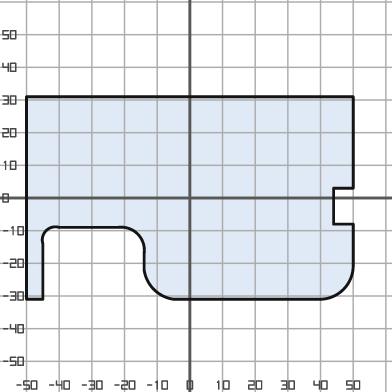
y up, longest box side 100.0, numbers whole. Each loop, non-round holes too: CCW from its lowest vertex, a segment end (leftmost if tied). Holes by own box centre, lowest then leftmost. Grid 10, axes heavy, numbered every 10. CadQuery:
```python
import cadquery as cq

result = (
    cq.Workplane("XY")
    .moveTo(-50.0, -31.0)
    .lineTo(-45.0, -31.0)
    .lineTo(-45.0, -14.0)
    .threePointArc((-44.0, -10.0), (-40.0, -9.0))
    .lineTo(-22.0, -9.0)
    .threePointArc((-16.0, -11.0), (-14.0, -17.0))
    .lineTo(-14.0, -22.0)
    .threePointArc((-11.0, -28.0), (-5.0, -31.0))
    .lineTo(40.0, -31.0)
    .threePointArc((47.0, -28.0), (50.0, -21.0))
    .lineTo(50.0, -8.0)
    .lineTo(44.0, -8.0)
    .lineTo(44.0, 3.0)
    .lineTo(50.0, 3.0)
    .lineTo(50.0, 31.0)
    .lineTo(-50.0, 31.0)
    .close()
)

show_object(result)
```